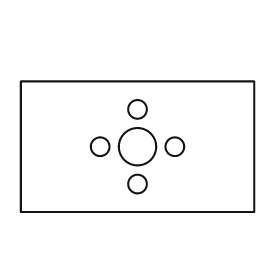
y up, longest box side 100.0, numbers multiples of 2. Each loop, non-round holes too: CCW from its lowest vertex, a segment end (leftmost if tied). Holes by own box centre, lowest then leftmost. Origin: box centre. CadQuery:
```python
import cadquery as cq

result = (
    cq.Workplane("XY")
    .moveTo(-50.0, -28.0)
    .lineTo(50.0, -28.0)
    .lineTo(50.0, 28.0)
    .lineTo(-50.0, 28.0)
    .close()
    .moveTo(0.0, -16.0)
    .circle(4.0)
    .moveTo(-16.0, 0.0)
    .circle(4.0)
    .moveTo(0.0, 0.0)
    .circle(8.0)
    .moveTo(16.0, 0.0)
    .circle(4.0)
    .moveTo(0.0, 16.0)
    .circle(4.0)
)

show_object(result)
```